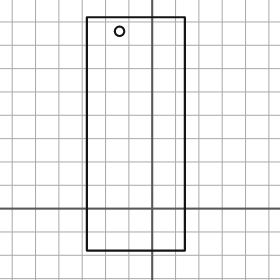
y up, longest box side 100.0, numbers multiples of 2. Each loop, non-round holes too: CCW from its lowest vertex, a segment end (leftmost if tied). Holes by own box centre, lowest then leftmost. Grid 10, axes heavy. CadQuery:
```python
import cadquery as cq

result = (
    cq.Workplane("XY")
    .moveTo(-28.0, -18.0)
    .lineTo(14.0, -18.0)
    .lineTo(14.0, 82.0)
    .lineTo(-28.0, 82.0)
    .close()
    .moveTo(-14.0, 76.0)
    .circle(2.0)
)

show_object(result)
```